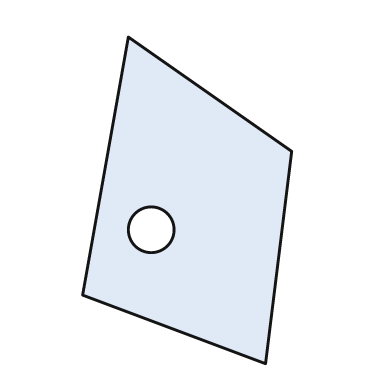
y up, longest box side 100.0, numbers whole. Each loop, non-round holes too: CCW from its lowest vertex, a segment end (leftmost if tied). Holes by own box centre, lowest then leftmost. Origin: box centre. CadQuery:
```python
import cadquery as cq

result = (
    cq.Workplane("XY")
    .moveTo(24.0, -50.0)
    .lineTo(32.0, 15.0)
    .lineTo(-18.0, 50.0)
    .lineTo(-32.0, -29.0)
    .close()
    .moveTo(-11.0, -9.0)
    .circle(7.0)
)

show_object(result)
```